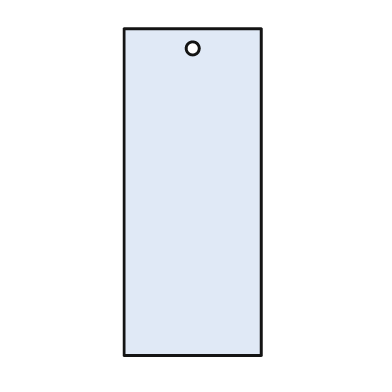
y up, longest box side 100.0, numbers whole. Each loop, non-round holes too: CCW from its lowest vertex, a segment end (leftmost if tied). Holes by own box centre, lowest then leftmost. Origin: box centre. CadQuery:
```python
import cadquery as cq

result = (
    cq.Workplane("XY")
    .moveTo(-21.0, -50.0)
    .lineTo(21.0, -50.0)
    .lineTo(21.0, 50.0)
    .lineTo(-21.0, 50.0)
    .close()
    .moveTo(0.0, 44.0)
    .circle(2.0)
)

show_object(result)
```